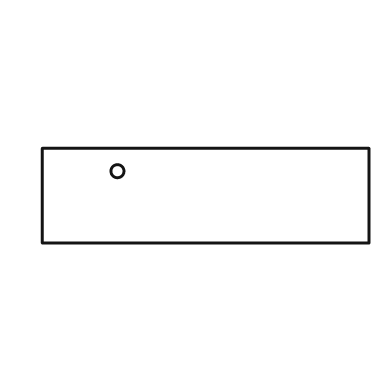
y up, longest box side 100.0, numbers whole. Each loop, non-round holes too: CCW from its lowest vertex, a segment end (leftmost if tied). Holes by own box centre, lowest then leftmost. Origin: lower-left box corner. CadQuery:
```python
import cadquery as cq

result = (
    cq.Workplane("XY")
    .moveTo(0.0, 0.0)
    .lineTo(100.0, 0.0)
    .lineTo(100.0, 29.0)
    .lineTo(0.0, 29.0)
    .close()
    .moveTo(23.0, 22.0)
    .circle(2.0)
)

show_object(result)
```